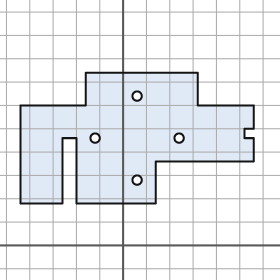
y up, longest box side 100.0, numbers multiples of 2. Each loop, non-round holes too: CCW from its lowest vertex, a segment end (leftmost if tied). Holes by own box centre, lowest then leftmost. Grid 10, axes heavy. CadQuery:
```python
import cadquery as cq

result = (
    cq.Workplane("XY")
    .moveTo(-44.0, 18.0)
    .lineTo(-26.0, 18.0)
    .lineTo(-26.0, 46.0)
    .lineTo(-20.0, 46.0)
    .lineTo(-20.0, 18.0)
    .lineTo(14.0, 18.0)
    .lineTo(14.0, 36.0)
    .lineTo(56.0, 36.0)
    .lineTo(56.0, 46.0)
    .lineTo(52.0, 46.0)
    .lineTo(52.0, 50.0)
    .lineTo(56.0, 50.0)
    .lineTo(56.0, 60.0)
    .lineTo(32.0, 60.0)
    .lineTo(32.0, 74.0)
    .lineTo(-16.0, 74.0)
    .lineTo(-16.0, 60.0)
    .lineTo(-44.0, 60.0)
    .close()
    .moveTo(6.0, 28.0)
    .circle(2.0)
    .moveTo(-12.0, 46.0)
    .circle(2.0)
    .moveTo(24.0, 46.0)
    .circle(2.0)
    .moveTo(6.0, 64.0)
    .circle(2.0)
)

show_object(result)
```